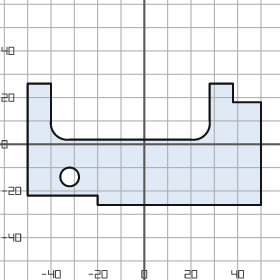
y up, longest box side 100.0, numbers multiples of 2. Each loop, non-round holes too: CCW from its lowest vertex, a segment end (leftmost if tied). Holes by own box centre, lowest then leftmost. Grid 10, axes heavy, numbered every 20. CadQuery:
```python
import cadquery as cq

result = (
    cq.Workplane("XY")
    .moveTo(-20.0, -26.0)
    .lineTo(50.0, -26.0)
    .lineTo(50.0, 18.0)
    .lineTo(38.0, 18.0)
    .lineTo(38.0, 26.0)
    .lineTo(28.0, 26.0)
    .lineTo(28.0, 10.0)
    .threePointArc((26.0, 4.0), (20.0, 2.0))
    .lineTo(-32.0, 2.0)
    .threePointArc((-38.0, 4.0), (-40.0, 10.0))
    .lineTo(-40.0, 26.0)
    .lineTo(-50.0, 26.0)
    .lineTo(-50.0, -22.0)
    .lineTo(-20.0, -22.0)
    .close()
    .moveTo(-32.0, -14.0)
    .circle(4.0)
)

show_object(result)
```